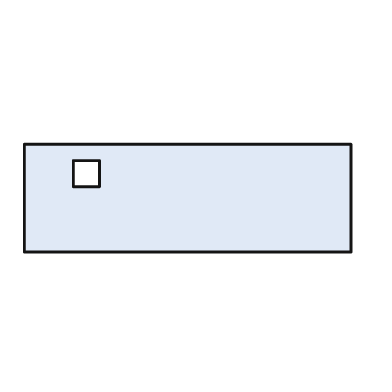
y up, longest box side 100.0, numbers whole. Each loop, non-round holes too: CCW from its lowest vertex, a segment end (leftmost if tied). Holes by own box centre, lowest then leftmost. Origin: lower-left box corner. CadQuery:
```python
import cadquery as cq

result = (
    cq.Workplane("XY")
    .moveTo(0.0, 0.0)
    .lineTo(100.0, 0.0)
    .lineTo(100.0, 33.0)
    .lineTo(0.0, 33.0)
    .close()
    .moveTo(15.0, 20.0)
    .lineTo(23.0, 20.0)
    .lineTo(23.0, 28.0)
    .lineTo(15.0, 28.0)
    .close()
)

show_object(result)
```